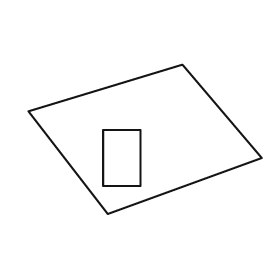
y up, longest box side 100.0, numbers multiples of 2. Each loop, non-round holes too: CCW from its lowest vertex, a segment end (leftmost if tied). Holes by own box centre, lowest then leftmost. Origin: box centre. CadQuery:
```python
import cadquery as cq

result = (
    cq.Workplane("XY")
    .moveTo(-16.0, -32.0)
    .lineTo(50.0, -8.0)
    .lineTo(16.0, 32.0)
    .lineTo(-50.0, 12.0)
    .close()
    .moveTo(-18.0, -20.0)
    .lineTo(-2.0, -20.0)
    .lineTo(-2.0, 4.0)
    .lineTo(-18.0, 4.0)
    .close()
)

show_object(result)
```